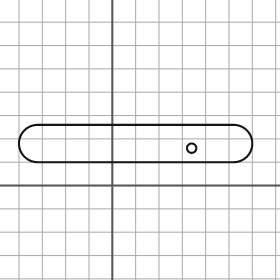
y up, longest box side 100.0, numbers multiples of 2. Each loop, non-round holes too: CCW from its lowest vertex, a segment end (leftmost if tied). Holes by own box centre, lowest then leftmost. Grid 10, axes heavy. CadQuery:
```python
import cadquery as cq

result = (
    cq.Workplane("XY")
    .moveTo(-32.0, 10.0)
    .lineTo(52.0, 10.0)
    .threePointArc((60.0, 18.0), (52.0, 26.0))
    .lineTo(-32.0, 26.0)
    .threePointArc((-40.0, 18.0), (-32.0, 10.0))
    .close()
    .moveTo(34.0, 16.0)
    .circle(2.0)
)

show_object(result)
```